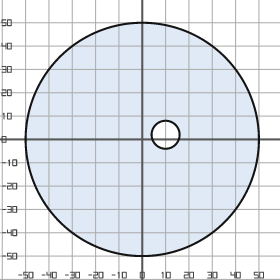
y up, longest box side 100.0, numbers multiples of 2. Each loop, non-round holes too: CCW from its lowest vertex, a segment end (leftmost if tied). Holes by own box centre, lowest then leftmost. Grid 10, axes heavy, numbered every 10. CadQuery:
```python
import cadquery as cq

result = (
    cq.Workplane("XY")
    .moveTo(0.0, 0.0)
    .circle(50.0)
    .moveTo(10.0, 2.0)
    .circle(6.0)
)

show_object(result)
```